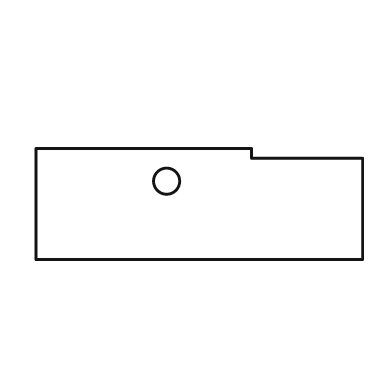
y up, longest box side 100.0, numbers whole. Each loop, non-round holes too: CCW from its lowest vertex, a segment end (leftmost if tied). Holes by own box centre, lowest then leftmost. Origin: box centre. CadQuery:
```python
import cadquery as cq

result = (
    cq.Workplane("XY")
    .moveTo(-50.0, -17.0)
    .lineTo(50.0, -17.0)
    .lineTo(50.0, 14.0)
    .lineTo(16.0, 14.0)
    .lineTo(16.0, 17.0)
    .lineTo(-50.0, 17.0)
    .close()
    .moveTo(-10.0, 7.0)
    .circle(4.0)
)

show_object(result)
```